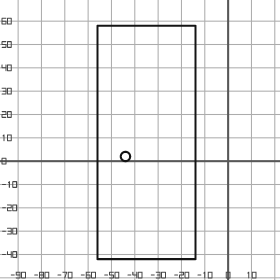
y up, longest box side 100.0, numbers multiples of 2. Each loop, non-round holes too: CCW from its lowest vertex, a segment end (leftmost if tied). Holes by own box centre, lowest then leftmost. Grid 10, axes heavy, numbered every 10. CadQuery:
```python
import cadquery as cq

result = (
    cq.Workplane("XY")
    .moveTo(-56.0, -42.0)
    .lineTo(-14.0, -42.0)
    .lineTo(-14.0, 58.0)
    .lineTo(-56.0, 58.0)
    .close()
    .moveTo(-44.0, 2.0)
    .circle(2.0)
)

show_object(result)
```